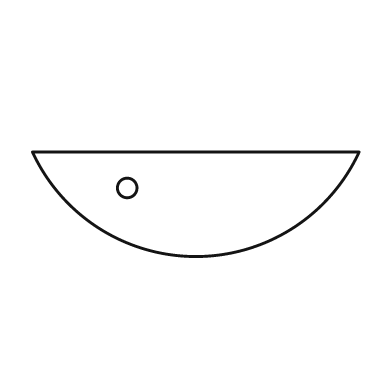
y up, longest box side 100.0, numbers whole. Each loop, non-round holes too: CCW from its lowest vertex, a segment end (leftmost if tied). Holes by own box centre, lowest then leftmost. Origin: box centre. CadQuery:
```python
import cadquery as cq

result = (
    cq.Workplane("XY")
    .moveTo(-50.0, 16.0)
    .threePointArc((0.0, -16.0), (50.0, 16.0))
    .close()
    .moveTo(-21.0, 5.0)
    .circle(3.0)
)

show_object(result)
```